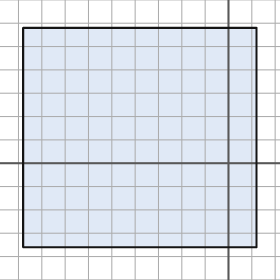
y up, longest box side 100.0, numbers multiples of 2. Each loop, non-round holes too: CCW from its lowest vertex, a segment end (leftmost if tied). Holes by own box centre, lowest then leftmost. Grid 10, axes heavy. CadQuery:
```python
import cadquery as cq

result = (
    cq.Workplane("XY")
    .moveTo(-88.0, -36.0)
    .lineTo(12.0, -36.0)
    .lineTo(12.0, 58.0)
    .lineTo(-88.0, 58.0)
    .close()
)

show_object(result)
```